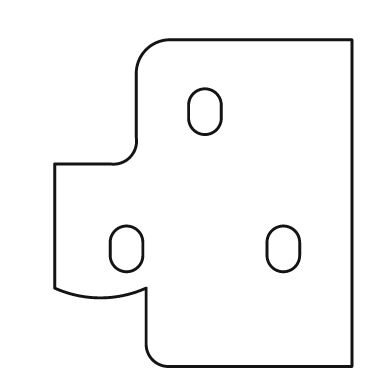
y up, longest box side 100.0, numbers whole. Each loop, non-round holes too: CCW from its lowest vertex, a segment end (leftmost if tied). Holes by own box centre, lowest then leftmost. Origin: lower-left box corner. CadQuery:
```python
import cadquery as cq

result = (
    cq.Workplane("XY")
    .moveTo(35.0, 0.0)
    .lineTo(91.0, 0.0)
    .lineTo(91.0, 100.0)
    .lineTo(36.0, 100.0)
    .threePointArc((28.0, 97.0), (25.0, 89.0))
    .lineTo(25.0, 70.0)
    .threePointArc((23.0, 64.0), (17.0, 62.0))
    .lineTo(0.0, 62.0)
    .lineTo(0.0, 24.0)
    .threePointArc((14.0, 21.0), (28.0, 24.0))
    .lineTo(28.0, 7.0)
    .threePointArc((30.0, 2.0), (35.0, 0.0))
    .close()
    .moveTo(17.0, 34.0)
    .threePointArc((22.0, 29.0), (27.0, 34.0))
    .lineTo(27.0, 38.0)
    .threePointArc((22.0, 43.0), (17.0, 38.0))
    .close()
    .moveTo(65.0, 34.0)
    .threePointArc((70.0, 29.0), (75.0, 34.0))
    .lineTo(75.0, 38.0)
    .threePointArc((70.0, 43.0), (65.0, 38.0))
    .close()
    .moveTo(41.0, 76.0)
    .threePointArc((46.0, 71.0), (51.0, 76.0))
    .lineTo(51.0, 80.0)
    .threePointArc((46.0, 85.0), (41.0, 80.0))
    .close()
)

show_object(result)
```